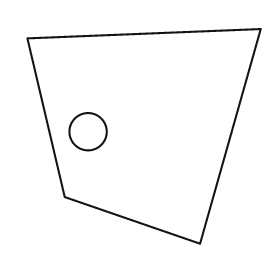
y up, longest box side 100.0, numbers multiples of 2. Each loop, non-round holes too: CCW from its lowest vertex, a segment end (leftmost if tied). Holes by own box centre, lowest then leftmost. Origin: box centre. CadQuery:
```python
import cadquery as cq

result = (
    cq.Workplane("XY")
    .moveTo(24.0, -46.0)
    .lineTo(50.0, 46.0)
    .lineTo(-50.0, 42.0)
    .lineTo(-34.0, -26.0)
    .close()
    .moveTo(-24.0, 2.0)
    .circle(8.0)
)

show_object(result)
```